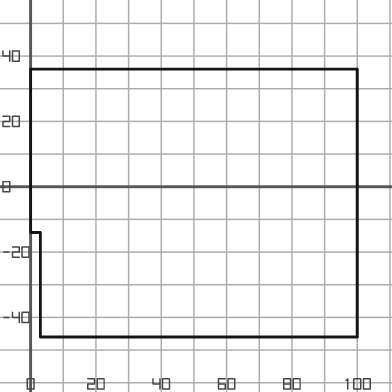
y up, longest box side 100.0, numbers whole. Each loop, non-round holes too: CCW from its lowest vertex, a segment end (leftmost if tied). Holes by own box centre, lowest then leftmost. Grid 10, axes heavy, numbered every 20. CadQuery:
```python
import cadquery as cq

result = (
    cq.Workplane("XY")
    .moveTo(3.0, -46.0)
    .lineTo(100.0, -46.0)
    .lineTo(100.0, 36.0)
    .lineTo(0.0, 36.0)
    .lineTo(0.0, -14.0)
    .lineTo(3.0, -14.0)
    .close()
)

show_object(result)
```